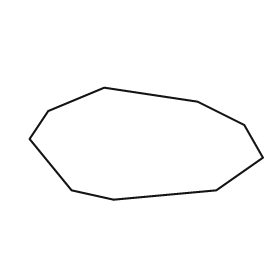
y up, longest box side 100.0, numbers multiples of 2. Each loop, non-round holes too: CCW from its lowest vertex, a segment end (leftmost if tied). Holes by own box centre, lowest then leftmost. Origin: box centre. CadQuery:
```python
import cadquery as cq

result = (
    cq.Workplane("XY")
    .moveTo(-14.0, -24.0)
    .lineTo(30.0, -20.0)
    .lineTo(50.0, -6.0)
    .lineTo(42.0, 8.0)
    .lineTo(22.0, 18.0)
    .lineTo(-18.0, 24.0)
    .lineTo(-42.0, 14.0)
    .lineTo(-50.0, 2.0)
    .lineTo(-32.0, -20.0)
    .close()
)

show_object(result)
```